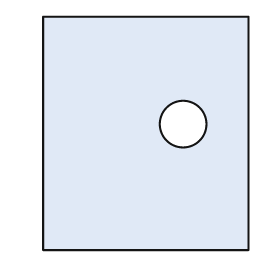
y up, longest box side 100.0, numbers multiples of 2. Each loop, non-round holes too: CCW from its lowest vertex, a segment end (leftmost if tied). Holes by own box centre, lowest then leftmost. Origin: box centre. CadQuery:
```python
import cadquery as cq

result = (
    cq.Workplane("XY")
    .moveTo(-44.0, -50.0)
    .lineTo(44.0, -50.0)
    .lineTo(44.0, 50.0)
    .lineTo(-44.0, 50.0)
    .close()
    .moveTo(16.0, 4.0)
    .circle(10.0)
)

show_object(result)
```